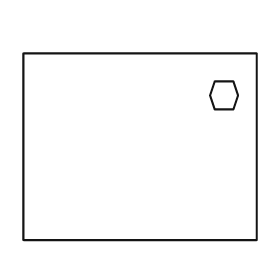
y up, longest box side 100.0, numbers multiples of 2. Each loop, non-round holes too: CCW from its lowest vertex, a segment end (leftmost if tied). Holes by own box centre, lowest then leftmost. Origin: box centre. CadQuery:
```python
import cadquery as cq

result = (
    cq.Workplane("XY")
    .moveTo(-50.0, -40.0)
    .lineTo(50.0, -40.0)
    .lineTo(50.0, 40.0)
    .lineTo(-50.0, 40.0)
    .close()
    .moveTo(32.0, 16.0)
    .lineTo(40.0, 16.0)
    .lineTo(42.0, 22.0)
    .lineTo(40.0, 28.0)
    .lineTo(32.0, 28.0)
    .lineTo(30.0, 22.0)
    .close()
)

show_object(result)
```